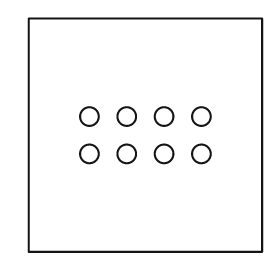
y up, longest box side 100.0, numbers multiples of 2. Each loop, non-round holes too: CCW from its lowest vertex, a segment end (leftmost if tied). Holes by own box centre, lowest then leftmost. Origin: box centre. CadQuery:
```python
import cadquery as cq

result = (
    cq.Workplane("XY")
    .moveTo(-50.0, -50.0)
    .lineTo(50.0, -50.0)
    .lineTo(50.0, 50.0)
    .lineTo(-50.0, 50.0)
    .close()
    .moveTo(-24.0, -8.0)
    .circle(4.0)
    .moveTo(-8.0, -8.0)
    .circle(4.0)
    .moveTo(8.0, -8.0)
    .circle(4.0)
    .moveTo(24.0, -8.0)
    .circle(4.0)
    .moveTo(-24.0, 8.0)
    .circle(4.0)
    .moveTo(-8.0, 8.0)
    .circle(4.0)
    .moveTo(8.0, 8.0)
    .circle(4.0)
    .moveTo(24.0, 8.0)
    .circle(4.0)
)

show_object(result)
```